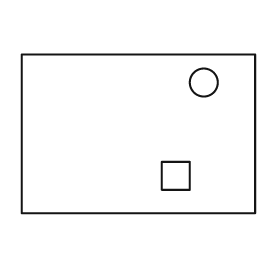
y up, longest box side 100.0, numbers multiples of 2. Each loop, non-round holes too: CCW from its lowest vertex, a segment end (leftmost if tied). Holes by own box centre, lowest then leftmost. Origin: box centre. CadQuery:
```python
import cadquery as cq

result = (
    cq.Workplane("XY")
    .moveTo(-50.0, -34.0)
    .lineTo(50.0, -34.0)
    .lineTo(50.0, 34.0)
    .lineTo(-50.0, 34.0)
    .close()
    .moveTo(10.0, -24.0)
    .lineTo(22.0, -24.0)
    .lineTo(22.0, -12.0)
    .lineTo(10.0, -12.0)
    .close()
    .moveTo(28.0, 22.0)
    .circle(6.0)
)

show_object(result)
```